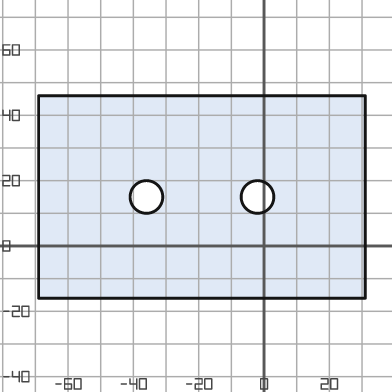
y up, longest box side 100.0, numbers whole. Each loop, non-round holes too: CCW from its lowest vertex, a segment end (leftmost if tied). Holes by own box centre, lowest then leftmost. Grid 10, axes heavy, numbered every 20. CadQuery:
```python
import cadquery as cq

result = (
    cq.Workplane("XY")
    .moveTo(-69.0, -16.0)
    .lineTo(31.0, -16.0)
    .lineTo(31.0, 46.0)
    .lineTo(-69.0, 46.0)
    .close()
    .moveTo(-36.0, 15.0)
    .circle(5.0)
    .moveTo(-2.0, 15.0)
    .circle(5.0)
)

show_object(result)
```